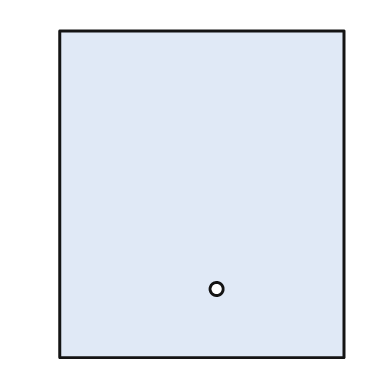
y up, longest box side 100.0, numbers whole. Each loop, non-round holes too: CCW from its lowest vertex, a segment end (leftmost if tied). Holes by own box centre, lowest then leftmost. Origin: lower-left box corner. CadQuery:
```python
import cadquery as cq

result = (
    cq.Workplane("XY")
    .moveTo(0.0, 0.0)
    .lineTo(87.0, 0.0)
    .lineTo(87.0, 100.0)
    .lineTo(0.0, 100.0)
    .close()
    .moveTo(48.0, 21.0)
    .circle(2.0)
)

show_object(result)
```